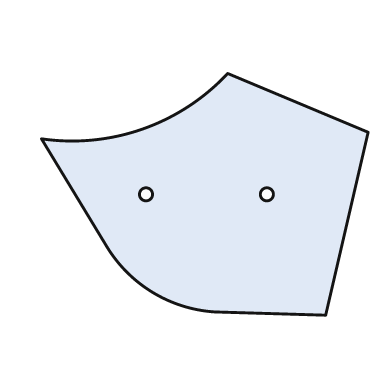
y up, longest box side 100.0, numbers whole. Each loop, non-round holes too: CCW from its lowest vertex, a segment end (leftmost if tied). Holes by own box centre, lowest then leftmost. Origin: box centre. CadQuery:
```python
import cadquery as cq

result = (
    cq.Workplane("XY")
    .moveTo(37.0, -37.0)
    .lineTo(50.0, 19.0)
    .lineTo(7.0, 37.0)
    .threePointArc((-19.0, 20.0), (-50.0, 17.0))
    .lineTo(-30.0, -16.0)
    .threePointArc((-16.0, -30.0), (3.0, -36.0))
    .close()
    .moveTo(-18.0, 0.0)
    .circle(2.0)
    .moveTo(19.0, 0.0)
    .circle(2.0)
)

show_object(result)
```